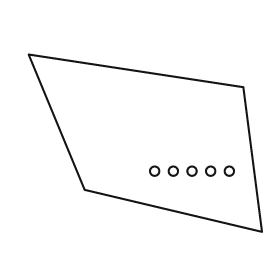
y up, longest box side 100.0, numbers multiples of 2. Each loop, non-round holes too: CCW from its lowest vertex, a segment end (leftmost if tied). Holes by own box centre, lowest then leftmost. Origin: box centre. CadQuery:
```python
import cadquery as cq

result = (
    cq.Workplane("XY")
    .moveTo(50.0, -38.0)
    .lineTo(42.0, 24.0)
    .lineTo(-50.0, 38.0)
    .lineTo(-26.0, -20.0)
    .close()
    .moveTo(4.0, -12.0)
    .circle(2.0)
    .moveTo(12.0, -12.0)
    .circle(2.0)
    .moveTo(20.0, -12.0)
    .circle(2.0)
    .moveTo(28.0, -12.0)
    .circle(2.0)
    .moveTo(36.0, -12.0)
    .circle(2.0)
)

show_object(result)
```